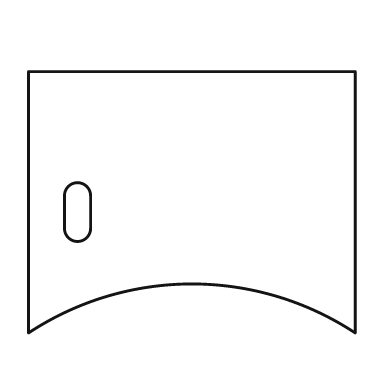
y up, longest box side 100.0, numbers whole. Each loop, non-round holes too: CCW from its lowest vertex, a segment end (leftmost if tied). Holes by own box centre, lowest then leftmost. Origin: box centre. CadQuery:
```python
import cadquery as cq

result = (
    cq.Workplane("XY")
    .moveTo(-50.0, -40.0)
    .threePointArc((0.0, -25.0), (50.0, -40.0))
    .lineTo(50.0, 40.0)
    .lineTo(-50.0, 40.0)
    .close()
    .moveTo(-39.0, -8.0)
    .threePointArc((-35.0, -12.0), (-31.0, -8.0))
    .lineTo(-31.0, 2.0)
    .threePointArc((-35.0, 6.0), (-39.0, 2.0))
    .close()
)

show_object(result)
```